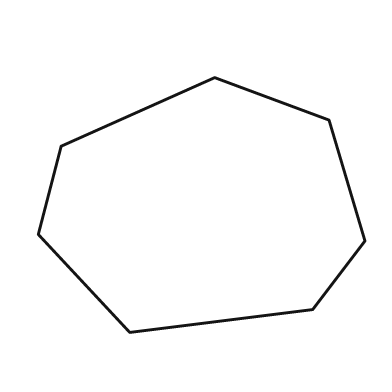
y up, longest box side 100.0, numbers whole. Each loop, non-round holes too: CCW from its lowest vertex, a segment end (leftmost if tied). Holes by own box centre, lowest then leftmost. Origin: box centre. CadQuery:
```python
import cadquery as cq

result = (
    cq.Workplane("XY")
    .moveTo(-22.0, -39.0)
    .lineTo(34.0, -32.0)
    .lineTo(50.0, -11.0)
    .lineTo(39.0, 26.0)
    .lineTo(4.0, 39.0)
    .lineTo(-43.0, 18.0)
    .lineTo(-50.0, -9.0)
    .close()
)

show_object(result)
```